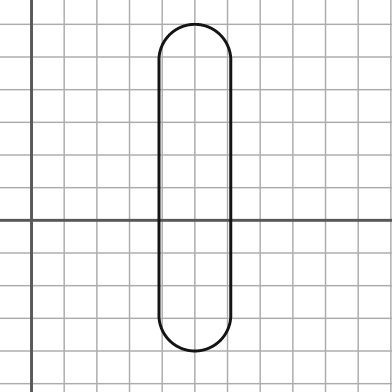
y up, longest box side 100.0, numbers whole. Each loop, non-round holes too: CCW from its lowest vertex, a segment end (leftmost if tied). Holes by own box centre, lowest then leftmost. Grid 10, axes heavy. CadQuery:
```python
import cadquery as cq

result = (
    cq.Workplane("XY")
    .moveTo(39.0, -29.0)
    .threePointArc((50.0, -40.0), (61.0, -29.0))
    .lineTo(61.0, 49.0)
    .threePointArc((50.0, 60.0), (39.0, 49.0))
    .close()
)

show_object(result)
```